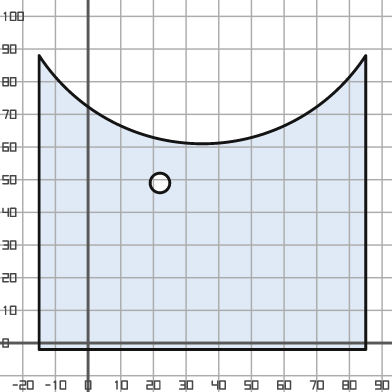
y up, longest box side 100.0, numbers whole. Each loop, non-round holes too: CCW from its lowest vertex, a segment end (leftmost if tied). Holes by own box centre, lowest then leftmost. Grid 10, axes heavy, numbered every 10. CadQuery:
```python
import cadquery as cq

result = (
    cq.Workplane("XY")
    .moveTo(-15.0, -2.0)
    .lineTo(85.0, -2.0)
    .lineTo(85.0, 88.0)
    .threePointArc((35.0, 61.0), (-15.0, 88.0))
    .close()
    .moveTo(22.0, 49.0)
    .circle(3.0)
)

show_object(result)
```